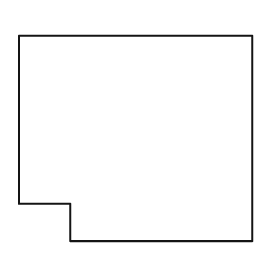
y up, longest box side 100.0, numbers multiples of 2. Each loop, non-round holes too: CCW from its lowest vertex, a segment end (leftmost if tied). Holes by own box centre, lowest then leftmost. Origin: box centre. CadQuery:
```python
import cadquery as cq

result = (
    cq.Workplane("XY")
    .moveTo(-28.0, -44.0)
    .lineTo(50.0, -44.0)
    .lineTo(50.0, 44.0)
    .lineTo(-50.0, 44.0)
    .lineTo(-50.0, -28.0)
    .lineTo(-28.0, -28.0)
    .close()
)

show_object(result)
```